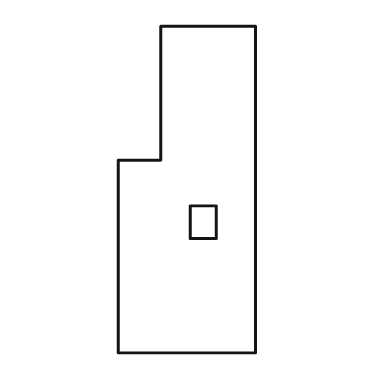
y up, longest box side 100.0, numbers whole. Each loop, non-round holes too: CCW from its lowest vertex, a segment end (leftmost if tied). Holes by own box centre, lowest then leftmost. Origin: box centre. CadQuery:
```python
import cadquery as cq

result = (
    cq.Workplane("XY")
    .moveTo(-21.0, -50.0)
    .lineTo(21.0, -50.0)
    .lineTo(21.0, 50.0)
    .lineTo(-8.0, 50.0)
    .lineTo(-8.0, 9.0)
    .lineTo(-21.0, 9.0)
    .close()
    .moveTo(1.0, -15.0)
    .lineTo(9.0, -15.0)
    .lineTo(9.0, -5.0)
    .lineTo(1.0, -5.0)
    .close()
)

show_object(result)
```